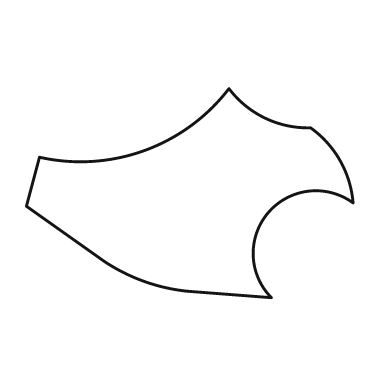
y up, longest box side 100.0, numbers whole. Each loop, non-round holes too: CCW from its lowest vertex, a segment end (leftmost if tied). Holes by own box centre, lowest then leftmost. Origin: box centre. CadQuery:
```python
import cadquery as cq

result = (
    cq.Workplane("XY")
    .moveTo(25.0, -32.0)
    .threePointArc((24.0, -6.0), (50.0, -3.0))
    .threePointArc((46.0, 10.0), (37.0, 20.0))
    .threePointArc((23.0, 23.0), (12.0, 32.0))
    .threePointArc((-14.0, 13.0), (-46.0, 11.0))
    .lineTo(-50.0, -4.0)
    .lineTo(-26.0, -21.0)
    .threePointArc((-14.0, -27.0), (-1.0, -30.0))
    .close()
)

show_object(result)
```